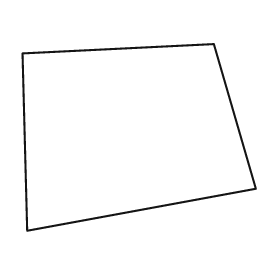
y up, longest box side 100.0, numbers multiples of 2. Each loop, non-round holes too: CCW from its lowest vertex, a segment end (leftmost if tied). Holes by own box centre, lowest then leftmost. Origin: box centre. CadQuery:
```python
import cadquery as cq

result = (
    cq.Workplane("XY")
    .moveTo(-48.0, -40.0)
    .lineTo(50.0, -22.0)
    .lineTo(32.0, 40.0)
    .lineTo(-50.0, 36.0)
    .close()
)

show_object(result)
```